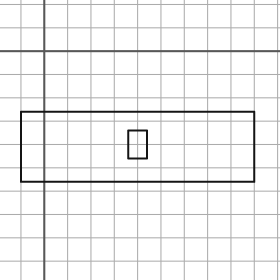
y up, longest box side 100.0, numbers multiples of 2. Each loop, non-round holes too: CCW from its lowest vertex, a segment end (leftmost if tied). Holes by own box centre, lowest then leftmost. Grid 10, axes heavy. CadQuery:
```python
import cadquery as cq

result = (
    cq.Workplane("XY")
    .moveTo(-10.0, -56.0)
    .lineTo(90.0, -56.0)
    .lineTo(90.0, -26.0)
    .lineTo(-10.0, -26.0)
    .close()
    .moveTo(36.0, -46.0)
    .lineTo(44.0, -46.0)
    .lineTo(44.0, -34.0)
    .lineTo(36.0, -34.0)
    .close()
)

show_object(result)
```